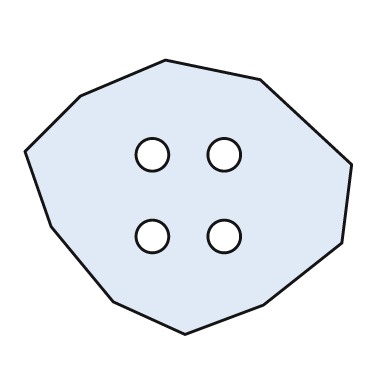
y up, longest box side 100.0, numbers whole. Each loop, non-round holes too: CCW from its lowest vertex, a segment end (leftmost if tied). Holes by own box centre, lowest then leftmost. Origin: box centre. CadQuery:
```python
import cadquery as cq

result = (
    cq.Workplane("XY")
    .moveTo(-1.0, -42.0)
    .lineTo(23.0, -33.0)
    .lineTo(47.0, -14.0)
    .lineTo(50.0, 10.0)
    .lineTo(22.0, 36.0)
    .lineTo(-7.0, 42.0)
    .lineTo(-33.0, 31.0)
    .lineTo(-50.0, 14.0)
    .lineTo(-42.0, -9.0)
    .lineTo(-23.0, -32.0)
    .close()
    .moveTo(-11.0, -12.0)
    .circle(5.0)
    .moveTo(11.0, -12.0)
    .circle(5.0)
    .moveTo(-11.0, 13.0)
    .circle(5.0)
    .moveTo(11.0, 13.0)
    .circle(5.0)
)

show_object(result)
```